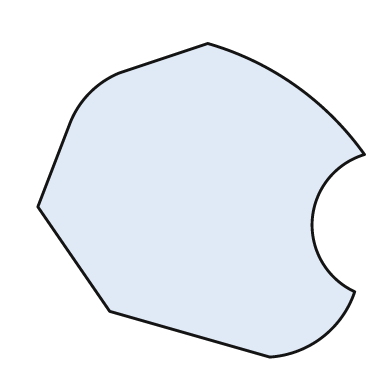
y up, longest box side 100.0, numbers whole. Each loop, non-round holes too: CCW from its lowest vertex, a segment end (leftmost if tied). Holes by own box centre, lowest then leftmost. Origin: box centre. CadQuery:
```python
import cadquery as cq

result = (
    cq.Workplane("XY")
    .moveTo(21.0, -48.0)
    .threePointArc((37.0, -42.0), (47.0, -28.0))
    .threePointArc((34.0, -6.0), (50.0, 14.0))
    .threePointArc((29.0, 35.0), (2.0, 48.0))
    .lineTo(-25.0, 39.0)
    .threePointArc((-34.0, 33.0), (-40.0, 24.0))
    .lineTo(-50.0, -2.0)
    .lineTo(-28.0, -34.0)
    .close()
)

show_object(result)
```